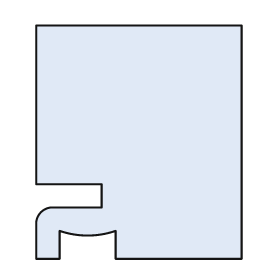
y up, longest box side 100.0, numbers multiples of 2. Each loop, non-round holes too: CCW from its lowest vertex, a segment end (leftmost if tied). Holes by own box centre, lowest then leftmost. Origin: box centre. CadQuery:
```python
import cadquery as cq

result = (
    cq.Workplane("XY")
    .moveTo(-44.0, -50.0)
    .lineTo(-34.0, -50.0)
    .lineTo(-34.0, -38.0)
    .threePointArc((-22.0, -40.0), (-10.0, -38.0))
    .lineTo(-10.0, -50.0)
    .lineTo(44.0, -50.0)
    .lineTo(44.0, 50.0)
    .lineTo(-44.0, 50.0)
    .lineTo(-44.0, -18.0)
    .lineTo(-16.0, -18.0)
    .lineTo(-16.0, -28.0)
    .lineTo(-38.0, -28.0)
    .threePointArc((-42.0, -30.0), (-44.0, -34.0))
    .close()
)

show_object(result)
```